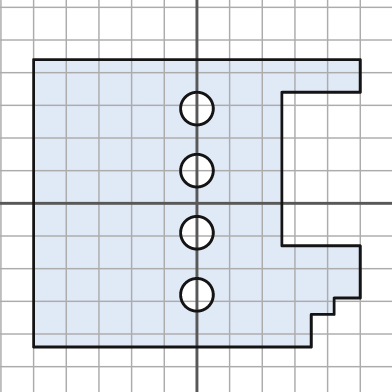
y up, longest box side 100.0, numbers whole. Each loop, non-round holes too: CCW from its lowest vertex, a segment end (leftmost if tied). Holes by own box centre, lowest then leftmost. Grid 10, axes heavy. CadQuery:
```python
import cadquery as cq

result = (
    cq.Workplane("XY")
    .moveTo(-50.0, -44.0)
    .lineTo(35.0, -44.0)
    .lineTo(35.0, -34.0)
    .lineTo(42.0, -34.0)
    .lineTo(42.0, -29.0)
    .lineTo(50.0, -29.0)
    .lineTo(50.0, -13.0)
    .lineTo(26.0, -13.0)
    .lineTo(26.0, 34.0)
    .lineTo(50.0, 34.0)
    .lineTo(50.0, 44.0)
    .lineTo(-50.0, 44.0)
    .close()
    .moveTo(0.0, -28.0)
    .circle(5.0)
    .moveTo(0.0, -9.0)
    .circle(5.0)
    .moveTo(0.0, 10.0)
    .circle(5.0)
    .moveTo(0.0, 29.0)
    .circle(5.0)
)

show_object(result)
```